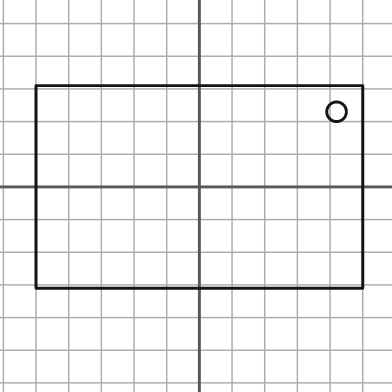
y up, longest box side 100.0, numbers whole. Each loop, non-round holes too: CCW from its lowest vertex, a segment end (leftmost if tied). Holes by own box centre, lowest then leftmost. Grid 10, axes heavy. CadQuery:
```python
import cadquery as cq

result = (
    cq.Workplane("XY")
    .moveTo(-50.0, -31.0)
    .lineTo(50.0, -31.0)
    .lineTo(50.0, 31.0)
    .lineTo(-50.0, 31.0)
    .close()
    .moveTo(42.0, 23.0)
    .circle(3.0)
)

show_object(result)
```